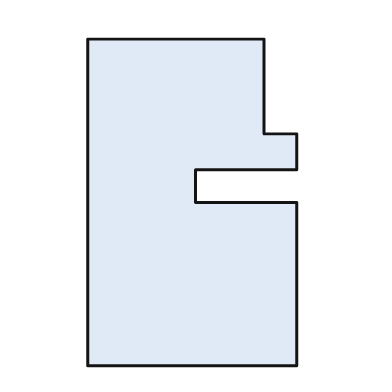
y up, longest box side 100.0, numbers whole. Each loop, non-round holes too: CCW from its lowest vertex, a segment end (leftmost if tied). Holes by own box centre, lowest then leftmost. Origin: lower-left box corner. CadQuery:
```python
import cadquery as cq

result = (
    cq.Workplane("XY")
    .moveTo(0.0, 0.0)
    .lineTo(64.0, 0.0)
    .lineTo(64.0, 50.0)
    .lineTo(33.0, 50.0)
    .lineTo(33.0, 60.0)
    .lineTo(64.0, 60.0)
    .lineTo(64.0, 71.0)
    .lineTo(54.0, 71.0)
    .lineTo(54.0, 100.0)
    .lineTo(0.0, 100.0)
    .close()
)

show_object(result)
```